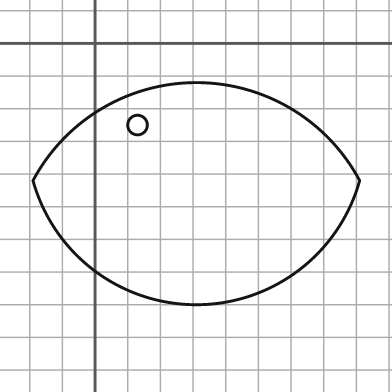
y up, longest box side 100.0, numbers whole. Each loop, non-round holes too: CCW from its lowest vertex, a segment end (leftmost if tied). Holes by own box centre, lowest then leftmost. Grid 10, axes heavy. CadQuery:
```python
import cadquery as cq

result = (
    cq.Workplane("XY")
    .moveTo(-19.0, -42.0)
    .threePointArc((31.0, -80.0), (81.0, -42.0))
    .threePointArc((31.0, -12.0), (-19.0, -42.0))
    .close()
    .moveTo(13.0, -25.0)
    .circle(3.0)
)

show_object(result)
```